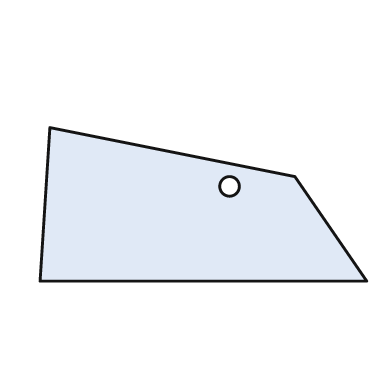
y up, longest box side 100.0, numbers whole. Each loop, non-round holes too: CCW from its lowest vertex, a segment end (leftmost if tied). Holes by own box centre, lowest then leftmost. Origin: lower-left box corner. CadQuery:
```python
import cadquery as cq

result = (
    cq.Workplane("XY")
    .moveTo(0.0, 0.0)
    .lineTo(100.0, 0.0)
    .lineTo(78.0, 32.0)
    .lineTo(3.0, 47.0)
    .close()
    .moveTo(58.0, 29.0)
    .circle(3.0)
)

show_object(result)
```